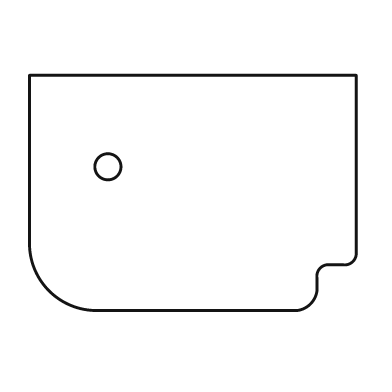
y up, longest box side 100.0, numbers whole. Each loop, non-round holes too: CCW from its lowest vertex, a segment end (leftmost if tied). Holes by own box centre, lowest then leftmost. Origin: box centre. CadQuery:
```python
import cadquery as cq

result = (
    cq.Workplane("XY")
    .moveTo(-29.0, -36.0)
    .lineTo(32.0, -36.0)
    .threePointArc((36.0, -34.0), (38.0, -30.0))
    .lineTo(38.0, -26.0)
    .threePointArc((39.0, -23.0), (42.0, -22.0))
    .lineTo(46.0, -22.0)
    .threePointArc((49.0, -21.0), (50.0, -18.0))
    .lineTo(50.0, 36.0)
    .lineTo(-50.0, 36.0)
    .lineTo(-50.0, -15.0)
    .threePointArc((-44.0, -30.0), (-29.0, -36.0))
    .close()
    .moveTo(-26.0, 8.0)
    .circle(4.0)
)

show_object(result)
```